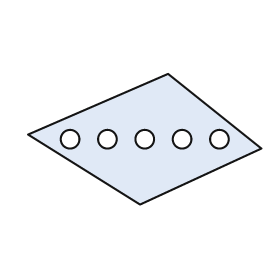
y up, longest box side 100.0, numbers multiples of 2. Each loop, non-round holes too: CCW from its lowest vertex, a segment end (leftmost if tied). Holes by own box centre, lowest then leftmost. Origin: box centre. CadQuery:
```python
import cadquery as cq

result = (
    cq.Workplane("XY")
    .moveTo(-2.0, -28.0)
    .lineTo(50.0, -4.0)
    .lineTo(10.0, 28.0)
    .lineTo(-50.0, 2.0)
    .close()
    .moveTo(-32.0, 0.0)
    .circle(4.0)
    .moveTo(-16.0, 0.0)
    .circle(4.0)
    .moveTo(0.0, 0.0)
    .circle(4.0)
    .moveTo(16.0, 0.0)
    .circle(4.0)
    .moveTo(32.0, 0.0)
    .circle(4.0)
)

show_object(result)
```